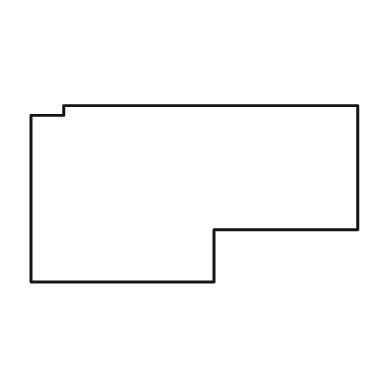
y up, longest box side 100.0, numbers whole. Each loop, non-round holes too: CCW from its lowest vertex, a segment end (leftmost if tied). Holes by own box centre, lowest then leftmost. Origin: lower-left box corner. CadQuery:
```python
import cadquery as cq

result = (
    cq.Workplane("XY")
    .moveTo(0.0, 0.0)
    .lineTo(56.0, 0.0)
    .lineTo(56.0, 16.0)
    .lineTo(100.0, 16.0)
    .lineTo(100.0, 54.0)
    .lineTo(10.0, 54.0)
    .lineTo(10.0, 51.0)
    .lineTo(0.0, 51.0)
    .close()
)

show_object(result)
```